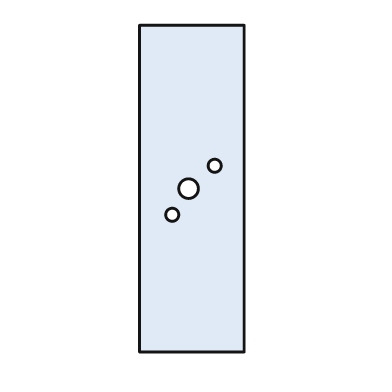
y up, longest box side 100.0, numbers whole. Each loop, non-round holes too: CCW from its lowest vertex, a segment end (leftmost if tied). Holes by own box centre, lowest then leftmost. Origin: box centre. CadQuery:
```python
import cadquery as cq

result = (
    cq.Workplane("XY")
    .moveTo(-16.0, -50.0)
    .lineTo(16.0, -50.0)
    .lineTo(16.0, 50.0)
    .lineTo(-16.0, 50.0)
    .close()
    .moveTo(-6.0, -8.0)
    .circle(2.0)
    .moveTo(-1.0, 0.0)
    .circle(3.0)
    .moveTo(7.0, 7.0)
    .circle(2.0)
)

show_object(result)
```